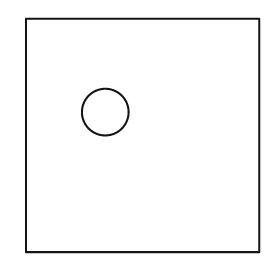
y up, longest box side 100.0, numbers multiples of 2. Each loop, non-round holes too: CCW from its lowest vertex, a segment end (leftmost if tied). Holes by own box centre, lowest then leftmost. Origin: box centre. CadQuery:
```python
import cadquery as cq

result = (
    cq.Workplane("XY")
    .moveTo(-50.0, -50.0)
    .lineTo(50.0, -50.0)
    .lineTo(50.0, 50.0)
    .lineTo(-50.0, 50.0)
    .close()
    .moveTo(-16.0, 10.0)
    .circle(10.0)
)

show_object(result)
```